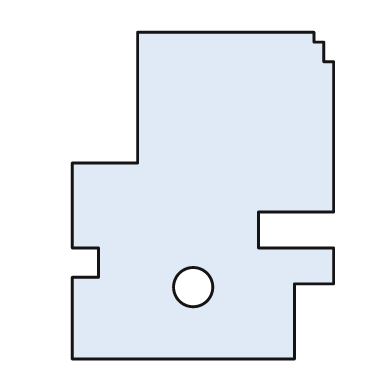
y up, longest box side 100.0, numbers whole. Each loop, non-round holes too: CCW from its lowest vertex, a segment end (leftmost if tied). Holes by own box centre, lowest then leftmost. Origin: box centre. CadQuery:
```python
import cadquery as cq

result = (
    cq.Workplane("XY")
    .moveTo(-40.0, -50.0)
    .lineTo(28.0, -50.0)
    .lineTo(28.0, -27.0)
    .lineTo(40.0, -27.0)
    .lineTo(40.0, -16.0)
    .lineTo(17.0, -16.0)
    .lineTo(17.0, -5.0)
    .lineTo(40.0, -5.0)
    .lineTo(40.0, 41.0)
    .lineTo(37.0, 41.0)
    .lineTo(37.0, 47.0)
    .lineTo(34.0, 47.0)
    .lineTo(34.0, 50.0)
    .lineTo(-20.0, 50.0)
    .lineTo(-20.0, 10.0)
    .lineTo(-40.0, 10.0)
    .lineTo(-40.0, -16.0)
    .lineTo(-32.0, -16.0)
    .lineTo(-32.0, -25.0)
    .lineTo(-40.0, -25.0)
    .close()
    .moveTo(-3.0, -28.0)
    .circle(6.0)
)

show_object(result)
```